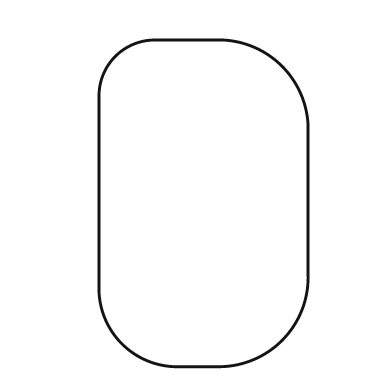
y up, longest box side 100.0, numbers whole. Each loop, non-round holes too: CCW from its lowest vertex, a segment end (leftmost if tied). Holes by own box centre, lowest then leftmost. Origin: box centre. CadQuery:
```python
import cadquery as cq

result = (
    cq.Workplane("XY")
    .moveTo(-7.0, -50.0)
    .lineTo(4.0, -50.0)
    .threePointArc((24.0, -42.0), (32.0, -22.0))
    .lineTo(32.0, 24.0)
    .threePointArc((24.0, 42.0), (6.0, 50.0))
    .lineTo(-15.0, 50.0)
    .threePointArc((-27.0, 45.0), (-32.0, 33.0))
    .lineTo(-32.0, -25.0)
    .threePointArc((-25.0, -43.0), (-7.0, -50.0))
    .close()
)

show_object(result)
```